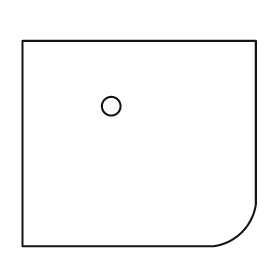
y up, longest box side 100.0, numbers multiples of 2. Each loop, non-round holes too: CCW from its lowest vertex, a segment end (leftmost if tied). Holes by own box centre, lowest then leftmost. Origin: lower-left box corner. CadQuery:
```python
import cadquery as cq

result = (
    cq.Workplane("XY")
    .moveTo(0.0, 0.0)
    .lineTo(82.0, 0.0)
    .threePointArc((94.0, 6.0), (100.0, 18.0))
    .lineTo(100.0, 88.0)
    .lineTo(0.0, 88.0)
    .close()
    .moveTo(38.0, 60.0)
    .circle(4.0)
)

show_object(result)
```